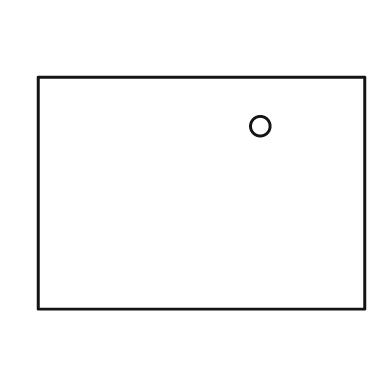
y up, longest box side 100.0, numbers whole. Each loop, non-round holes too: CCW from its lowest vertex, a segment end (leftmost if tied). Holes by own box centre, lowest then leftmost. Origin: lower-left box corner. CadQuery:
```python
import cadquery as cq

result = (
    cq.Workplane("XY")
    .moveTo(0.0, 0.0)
    .lineTo(100.0, 0.0)
    .lineTo(100.0, 71.0)
    .lineTo(0.0, 71.0)
    .close()
    .moveTo(68.0, 56.0)
    .circle(3.0)
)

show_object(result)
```